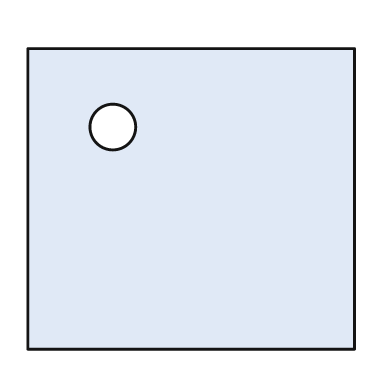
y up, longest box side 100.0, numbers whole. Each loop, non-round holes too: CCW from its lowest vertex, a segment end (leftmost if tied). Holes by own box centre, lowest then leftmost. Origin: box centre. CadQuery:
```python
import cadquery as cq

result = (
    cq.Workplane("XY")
    .moveTo(-50.0, -46.0)
    .lineTo(50.0, -46.0)
    .lineTo(50.0, 46.0)
    .lineTo(-50.0, 46.0)
    .close()
    .moveTo(-24.0, 22.0)
    .circle(7.0)
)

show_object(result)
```